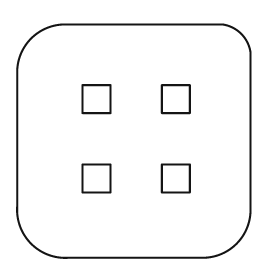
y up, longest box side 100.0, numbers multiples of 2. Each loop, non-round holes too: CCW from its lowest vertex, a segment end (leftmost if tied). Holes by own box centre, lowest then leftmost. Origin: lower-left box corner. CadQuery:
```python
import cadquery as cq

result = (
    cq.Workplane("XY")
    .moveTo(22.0, 0.0)
    .lineTo(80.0, 0.0)
    .threePointArc((94.0, 6.0), (100.0, 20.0))
    .lineTo(100.0, 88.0)
    .threePointArc((96.0, 96.0), (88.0, 100.0))
    .lineTo(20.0, 100.0)
    .threePointArc((6.0, 94.0), (0.0, 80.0))
    .lineTo(0.0, 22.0)
    .threePointArc((6.0, 6.0), (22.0, 0.0))
    .close()
    .moveTo(28.0, 28.0)
    .lineTo(40.0, 28.0)
    .lineTo(40.0, 40.0)
    .lineTo(28.0, 40.0)
    .close()
    .moveTo(62.0, 28.0)
    .lineTo(74.0, 28.0)
    .lineTo(74.0, 40.0)
    .lineTo(62.0, 40.0)
    .close()
    .moveTo(28.0, 62.0)
    .lineTo(40.0, 62.0)
    .lineTo(40.0, 74.0)
    .lineTo(28.0, 74.0)
    .close()
    .moveTo(62.0, 62.0)
    .lineTo(74.0, 62.0)
    .lineTo(74.0, 74.0)
    .lineTo(62.0, 74.0)
    .close()
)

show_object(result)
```